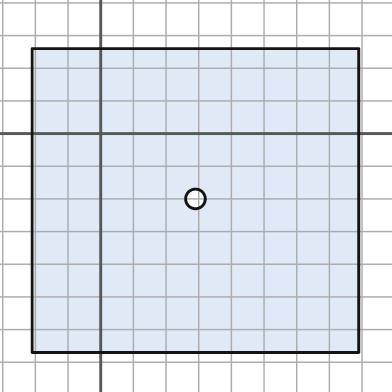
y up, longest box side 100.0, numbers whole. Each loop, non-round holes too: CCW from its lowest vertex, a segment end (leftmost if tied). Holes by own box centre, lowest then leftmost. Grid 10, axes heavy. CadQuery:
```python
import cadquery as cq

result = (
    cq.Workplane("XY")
    .moveTo(-21.0, -67.0)
    .lineTo(79.0, -67.0)
    .lineTo(79.0, 26.0)
    .lineTo(-21.0, 26.0)
    .close()
    .moveTo(29.0, -20.0)
    .circle(3.0)
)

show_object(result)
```